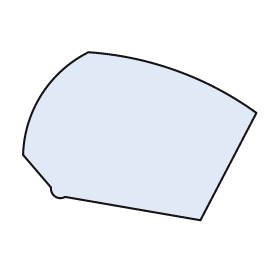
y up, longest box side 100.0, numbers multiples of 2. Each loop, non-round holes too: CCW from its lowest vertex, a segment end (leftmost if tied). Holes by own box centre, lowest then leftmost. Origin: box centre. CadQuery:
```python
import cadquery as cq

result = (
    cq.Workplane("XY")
    .moveTo(26.0, -36.0)
    .lineTo(50.0, 10.0)
    .threePointArc((16.0, 28.0), (-22.0, 36.0))
    .threePointArc((-42.0, 18.0), (-50.0, -8.0))
    .lineTo(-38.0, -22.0)
    .threePointArc((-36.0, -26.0), (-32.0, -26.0))
    .close()
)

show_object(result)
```